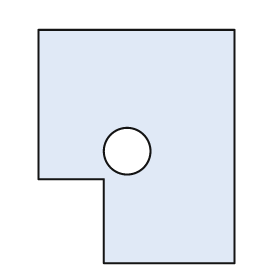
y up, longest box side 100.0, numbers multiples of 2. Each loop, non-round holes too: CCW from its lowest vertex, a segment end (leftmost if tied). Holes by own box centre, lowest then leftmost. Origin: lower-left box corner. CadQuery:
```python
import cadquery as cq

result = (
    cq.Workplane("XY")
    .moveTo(28.0, 0.0)
    .lineTo(84.0, 0.0)
    .lineTo(84.0, 100.0)
    .lineTo(0.0, 100.0)
    .lineTo(0.0, 36.0)
    .lineTo(28.0, 36.0)
    .close()
    .moveTo(38.0, 48.0)
    .circle(10.0)
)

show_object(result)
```